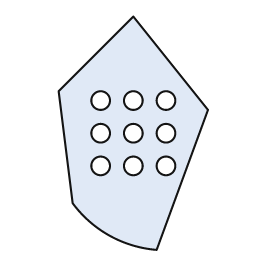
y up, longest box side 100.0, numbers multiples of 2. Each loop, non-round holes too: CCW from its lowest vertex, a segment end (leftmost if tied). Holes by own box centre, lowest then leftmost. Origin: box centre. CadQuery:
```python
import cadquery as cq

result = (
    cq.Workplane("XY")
    .moveTo(10.0, -50.0)
    .lineTo(32.0, 10.0)
    .lineTo(0.0, 50.0)
    .lineTo(-32.0, 18.0)
    .lineTo(-26.0, -30.0)
    .threePointArc((-10.0, -44.0), (10.0, -50.0))
    .close()
    .moveTo(-14.0, -14.0)
    .circle(4.0)
    .moveTo(0.0, -14.0)
    .circle(4.0)
    .moveTo(14.0, -14.0)
    .circle(4.0)
    .moveTo(-14.0, 0.0)
    .circle(4.0)
    .moveTo(0.0, 0.0)
    .circle(4.0)
    .moveTo(14.0, 0.0)
    .circle(4.0)
    .moveTo(-14.0, 14.0)
    .circle(4.0)
    .moveTo(0.0, 14.0)
    .circle(4.0)
    .moveTo(14.0, 14.0)
    .circle(4.0)
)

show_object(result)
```